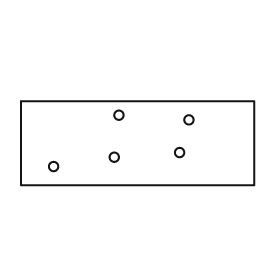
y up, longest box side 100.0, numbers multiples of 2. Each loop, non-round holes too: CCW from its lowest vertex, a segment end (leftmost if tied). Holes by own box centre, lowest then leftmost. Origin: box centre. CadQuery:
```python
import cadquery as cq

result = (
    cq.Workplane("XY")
    .moveTo(-50.0, -18.0)
    .lineTo(50.0, -18.0)
    .lineTo(50.0, 18.0)
    .lineTo(-50.0, 18.0)
    .close()
    .moveTo(-36.0, -10.0)
    .circle(2.0)
    .moveTo(-10.0, -6.0)
    .circle(2.0)
    .moveTo(18.0, -4.0)
    .circle(2.0)
    .moveTo(22.0, 10.0)
    .circle(2.0)
    .moveTo(-8.0, 12.0)
    .circle(2.0)
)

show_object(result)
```